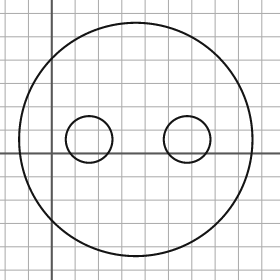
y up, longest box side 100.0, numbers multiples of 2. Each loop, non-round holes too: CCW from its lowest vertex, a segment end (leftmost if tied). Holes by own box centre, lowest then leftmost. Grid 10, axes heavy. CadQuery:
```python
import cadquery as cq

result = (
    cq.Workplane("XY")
    .moveTo(36.0, 6.0)
    .circle(50.0)
    .moveTo(16.0, 6.0)
    .circle(10.0)
    .moveTo(58.0, 6.0)
    .circle(10.0)
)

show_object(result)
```